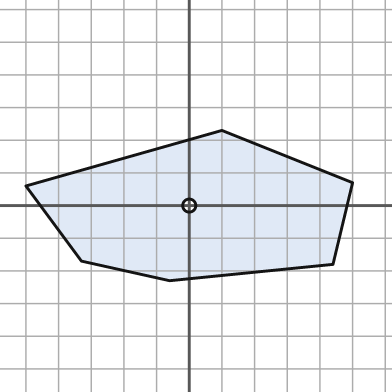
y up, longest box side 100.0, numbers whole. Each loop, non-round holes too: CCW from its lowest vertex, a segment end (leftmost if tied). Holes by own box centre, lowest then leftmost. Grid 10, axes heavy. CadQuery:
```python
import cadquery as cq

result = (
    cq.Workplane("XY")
    .moveTo(-6.0, -23.0)
    .lineTo(44.0, -18.0)
    .lineTo(50.0, 7.0)
    .lineTo(10.0, 23.0)
    .lineTo(-50.0, 6.0)
    .lineTo(-33.0, -17.0)
    .close()
    .moveTo(0.0, 0.0)
    .circle(2.0)
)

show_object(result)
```